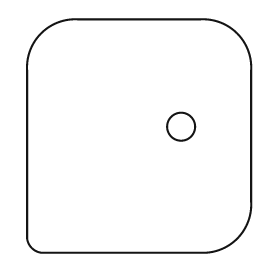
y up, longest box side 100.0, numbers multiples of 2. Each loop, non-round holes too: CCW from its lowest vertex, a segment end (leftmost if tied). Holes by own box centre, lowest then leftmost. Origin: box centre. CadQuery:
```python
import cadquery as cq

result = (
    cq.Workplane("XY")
    .moveTo(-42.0, -50.0)
    .lineTo(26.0, -50.0)
    .threePointArc((42.0, -44.0), (48.0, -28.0))
    .lineTo(48.0, 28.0)
    .threePointArc((42.0, 44.0), (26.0, 50.0))
    .lineTo(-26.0, 50.0)
    .threePointArc((-42.0, 44.0), (-48.0, 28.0))
    .lineTo(-48.0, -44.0)
    .threePointArc((-46.0, -48.0), (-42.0, -50.0))
    .close()
    .moveTo(18.0, 4.0)
    .circle(6.0)
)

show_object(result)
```